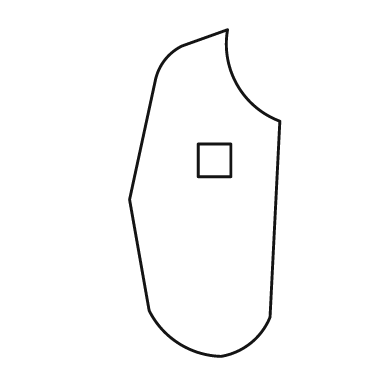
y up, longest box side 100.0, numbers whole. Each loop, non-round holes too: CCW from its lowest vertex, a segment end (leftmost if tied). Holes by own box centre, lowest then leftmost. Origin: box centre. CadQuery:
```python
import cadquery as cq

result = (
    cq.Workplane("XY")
    .moveTo(5.0, -50.0)
    .threePointArc((14.0, -46.0), (20.0, -38.0))
    .lineTo(23.0, 22.0)
    .threePointArc((10.0, 33.0), (7.0, 50.0))
    .lineTo(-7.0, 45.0)
    .threePointArc((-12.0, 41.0), (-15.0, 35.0))
    .lineTo(-23.0, -2.0)
    .lineTo(-17.0, -36.0)
    .threePointArc((-8.0, -46.0), (5.0, -50.0))
    .close()
    .moveTo(-2.0, 5.0)
    .lineTo(8.0, 5.0)
    .lineTo(8.0, 15.0)
    .lineTo(-2.0, 15.0)
    .close()
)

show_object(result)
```